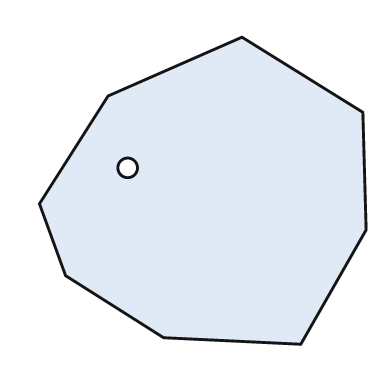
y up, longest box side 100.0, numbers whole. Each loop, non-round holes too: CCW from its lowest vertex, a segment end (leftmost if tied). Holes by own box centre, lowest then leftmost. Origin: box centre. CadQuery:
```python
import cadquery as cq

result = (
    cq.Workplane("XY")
    .moveTo(30.0, -47.0)
    .lineTo(50.0, -12.0)
    .lineTo(49.0, 24.0)
    .lineTo(12.0, 47.0)
    .lineTo(-29.0, 29.0)
    .lineTo(-50.0, -4.0)
    .lineTo(-42.0, -26.0)
    .lineTo(-12.0, -45.0)
    .close()
    .moveTo(-23.0, 7.0)
    .circle(3.0)
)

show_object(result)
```